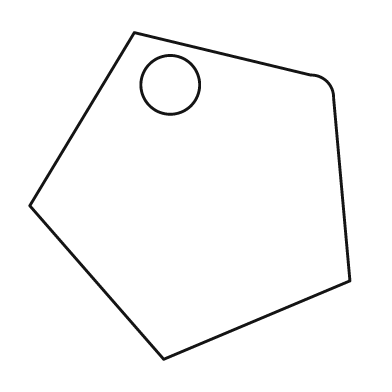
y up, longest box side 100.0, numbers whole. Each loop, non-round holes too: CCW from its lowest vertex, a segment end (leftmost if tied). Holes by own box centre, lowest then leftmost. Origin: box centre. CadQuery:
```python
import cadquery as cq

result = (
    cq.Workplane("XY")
    .moveTo(-8.0, -50.0)
    .lineTo(49.0, -26.0)
    .lineTo(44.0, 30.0)
    .threePointArc((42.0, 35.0), (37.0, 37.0))
    .lineTo(-17.0, 50.0)
    .lineTo(-49.0, -3.0)
    .close()
    .moveTo(-6.0, 34.0)
    .circle(9.0)
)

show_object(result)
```